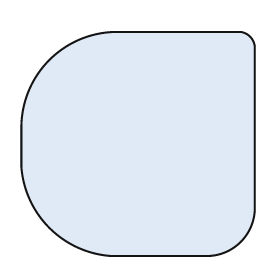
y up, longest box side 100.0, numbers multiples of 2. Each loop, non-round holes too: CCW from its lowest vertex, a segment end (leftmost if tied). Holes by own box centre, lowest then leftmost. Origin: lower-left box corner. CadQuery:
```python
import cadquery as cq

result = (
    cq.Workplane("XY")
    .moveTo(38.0, 0.0)
    .lineTo(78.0, 0.0)
    .threePointArc((94.0, 6.0), (100.0, 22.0))
    .lineTo(100.0, 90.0)
    .threePointArc((98.0, 94.0), (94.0, 96.0))
    .lineTo(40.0, 96.0)
    .threePointArc((12.0, 84.0), (0.0, 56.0))
    .lineTo(0.0, 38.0)
    .threePointArc((12.0, 12.0), (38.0, 0.0))
    .close()
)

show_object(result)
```